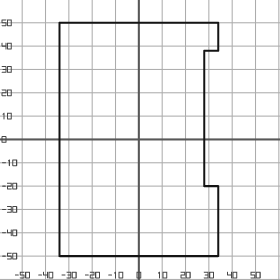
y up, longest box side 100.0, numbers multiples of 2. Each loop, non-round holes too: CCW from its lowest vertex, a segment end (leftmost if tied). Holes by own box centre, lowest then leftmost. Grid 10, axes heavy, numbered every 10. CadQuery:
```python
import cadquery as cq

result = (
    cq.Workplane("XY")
    .moveTo(-34.0, -50.0)
    .lineTo(34.0, -50.0)
    .lineTo(34.0, -20.0)
    .lineTo(28.0, -20.0)
    .lineTo(28.0, 38.0)
    .lineTo(34.0, 38.0)
    .lineTo(34.0, 50.0)
    .lineTo(-34.0, 50.0)
    .close()
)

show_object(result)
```